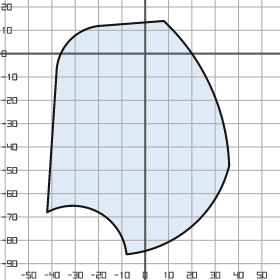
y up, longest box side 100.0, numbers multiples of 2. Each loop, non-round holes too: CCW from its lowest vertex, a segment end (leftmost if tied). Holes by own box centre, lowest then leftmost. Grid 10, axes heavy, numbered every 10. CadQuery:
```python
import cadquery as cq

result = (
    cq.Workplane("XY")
    .moveTo(-8.0, -86.0)
    .threePointArc((20.0, -74.0), (36.0, -48.0))
    .threePointArc((28.0, -14.0), (8.0, 14.0))
    .lineTo(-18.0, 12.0)
    .threePointArc((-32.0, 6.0), (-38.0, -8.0))
    .lineTo(-42.0, -68.0)
    .threePointArc((-20.0, -68.0), (-8.0, -86.0))
    .close()
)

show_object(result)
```